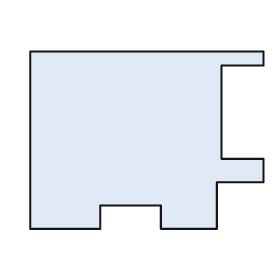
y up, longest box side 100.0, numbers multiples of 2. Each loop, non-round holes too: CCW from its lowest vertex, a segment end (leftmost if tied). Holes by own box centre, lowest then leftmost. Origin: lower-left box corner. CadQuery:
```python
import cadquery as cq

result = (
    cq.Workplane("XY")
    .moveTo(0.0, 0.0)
    .lineTo(30.0, 0.0)
    .lineTo(30.0, 10.0)
    .lineTo(56.0, 10.0)
    .lineTo(56.0, 0.0)
    .lineTo(80.0, 0.0)
    .lineTo(80.0, 20.0)
    .lineTo(100.0, 20.0)
    .lineTo(100.0, 30.0)
    .lineTo(82.0, 30.0)
    .lineTo(82.0, 70.0)
    .lineTo(100.0, 70.0)
    .lineTo(100.0, 76.0)
    .lineTo(0.0, 76.0)
    .close()
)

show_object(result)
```